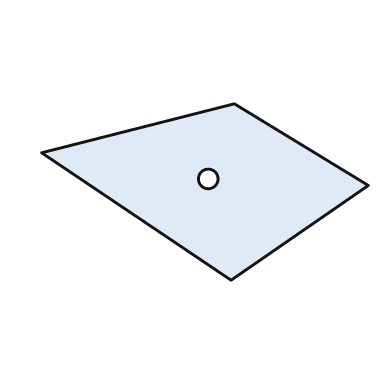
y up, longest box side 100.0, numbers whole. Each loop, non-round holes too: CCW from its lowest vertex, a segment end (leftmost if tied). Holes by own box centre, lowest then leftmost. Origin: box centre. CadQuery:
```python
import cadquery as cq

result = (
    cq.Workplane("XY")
    .moveTo(8.0, -27.0)
    .lineTo(50.0, 2.0)
    .lineTo(9.0, 27.0)
    .lineTo(-50.0, 12.0)
    .close()
    .moveTo(1.0, 4.0)
    .circle(3.0)
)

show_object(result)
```